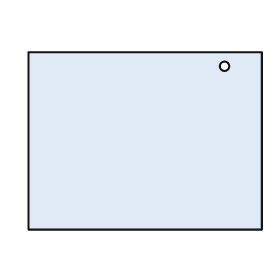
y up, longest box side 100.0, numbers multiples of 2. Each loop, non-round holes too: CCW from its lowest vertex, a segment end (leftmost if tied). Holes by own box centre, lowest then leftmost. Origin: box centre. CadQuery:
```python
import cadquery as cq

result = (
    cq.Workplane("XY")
    .moveTo(-50.0, -38.0)
    .lineTo(50.0, -38.0)
    .lineTo(50.0, 38.0)
    .lineTo(-50.0, 38.0)
    .close()
    .moveTo(34.0, 32.0)
    .circle(2.0)
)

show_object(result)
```